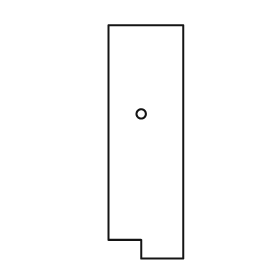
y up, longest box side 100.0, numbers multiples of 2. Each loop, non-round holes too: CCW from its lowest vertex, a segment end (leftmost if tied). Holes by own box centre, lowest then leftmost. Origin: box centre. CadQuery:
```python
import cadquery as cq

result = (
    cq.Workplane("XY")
    .moveTo(-2.0, -50.0)
    .lineTo(16.0, -50.0)
    .lineTo(16.0, 50.0)
    .lineTo(-16.0, 50.0)
    .lineTo(-16.0, -42.0)
    .lineTo(-2.0, -42.0)
    .close()
    .moveTo(-2.0, 12.0)
    .circle(2.0)
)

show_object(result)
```